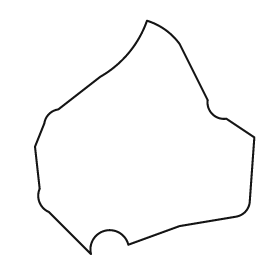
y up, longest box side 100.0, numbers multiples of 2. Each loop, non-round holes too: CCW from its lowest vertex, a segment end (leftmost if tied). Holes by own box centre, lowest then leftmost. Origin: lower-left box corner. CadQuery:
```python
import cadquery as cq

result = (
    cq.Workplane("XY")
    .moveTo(24.0, 0.0)
    .threePointArc((30.0, 10.0), (40.0, 4.0))
    .lineTo(62.0, 12.0)
    .lineTo(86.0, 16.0)
    .threePointArc((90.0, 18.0), (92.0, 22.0))
    .lineTo(94.0, 50.0)
    .lineTo(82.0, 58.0)
    .threePointArc((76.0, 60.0), (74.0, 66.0))
    .lineTo(62.0, 90.0)
    .threePointArc((56.0, 96.0), (48.0, 100.0))
    .threePointArc((40.0, 86.0), (28.0, 76.0))
    .lineTo(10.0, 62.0)
    .threePointArc((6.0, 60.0), (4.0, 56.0))
    .lineTo(0.0, 46.0)
    .lineTo(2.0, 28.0)
    .threePointArc((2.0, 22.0), (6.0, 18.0))
    .close()
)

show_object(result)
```